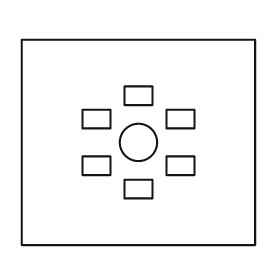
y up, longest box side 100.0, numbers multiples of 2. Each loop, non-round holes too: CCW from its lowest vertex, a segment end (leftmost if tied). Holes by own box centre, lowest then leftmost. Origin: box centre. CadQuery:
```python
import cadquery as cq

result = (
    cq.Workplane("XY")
    .moveTo(-50.0, -44.0)
    .lineTo(50.0, -44.0)
    .lineTo(50.0, 44.0)
    .lineTo(-50.0, 44.0)
    .close()
    .moveTo(-6.0, -24.0)
    .lineTo(6.0, -24.0)
    .lineTo(6.0, -16.0)
    .lineTo(-6.0, -16.0)
    .close()
    .moveTo(-24.0, -14.0)
    .lineTo(-12.0, -14.0)
    .lineTo(-12.0, -6.0)
    .lineTo(-24.0, -6.0)
    .close()
    .moveTo(12.0, -14.0)
    .lineTo(24.0, -14.0)
    .lineTo(24.0, -6.0)
    .lineTo(12.0, -6.0)
    .close()
    .moveTo(0.0, 0.0)
    .circle(8.0)
    .moveTo(-24.0, 6.0)
    .lineTo(-12.0, 6.0)
    .lineTo(-12.0, 14.0)
    .lineTo(-24.0, 14.0)
    .close()
    .moveTo(12.0, 6.0)
    .lineTo(24.0, 6.0)
    .lineTo(24.0, 14.0)
    .lineTo(12.0, 14.0)
    .close()
    .moveTo(-6.0, 16.0)
    .lineTo(6.0, 16.0)
    .lineTo(6.0, 24.0)
    .lineTo(-6.0, 24.0)
    .close()
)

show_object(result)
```